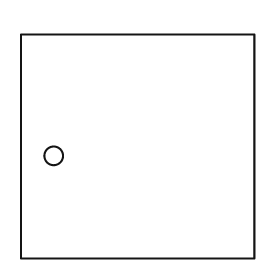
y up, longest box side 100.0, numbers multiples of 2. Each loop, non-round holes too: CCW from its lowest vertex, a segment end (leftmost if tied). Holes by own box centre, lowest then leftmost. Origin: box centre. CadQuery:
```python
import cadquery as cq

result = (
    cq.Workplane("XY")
    .moveTo(-50.0, -48.0)
    .lineTo(50.0, -48.0)
    .lineTo(50.0, 48.0)
    .lineTo(-50.0, 48.0)
    .close()
    .moveTo(-36.0, -4.0)
    .circle(4.0)
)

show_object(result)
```